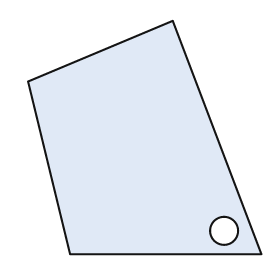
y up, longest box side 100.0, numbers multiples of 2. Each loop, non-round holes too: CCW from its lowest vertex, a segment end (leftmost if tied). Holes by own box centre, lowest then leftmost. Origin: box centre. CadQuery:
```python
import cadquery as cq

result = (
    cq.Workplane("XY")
    .moveTo(-32.0, -50.0)
    .lineTo(50.0, -50.0)
    .lineTo(12.0, 50.0)
    .lineTo(-50.0, 24.0)
    .close()
    .moveTo(34.0, -40.0)
    .circle(6.0)
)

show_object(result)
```